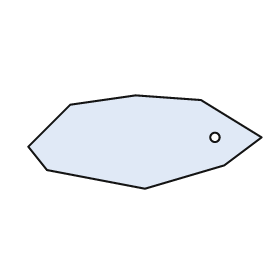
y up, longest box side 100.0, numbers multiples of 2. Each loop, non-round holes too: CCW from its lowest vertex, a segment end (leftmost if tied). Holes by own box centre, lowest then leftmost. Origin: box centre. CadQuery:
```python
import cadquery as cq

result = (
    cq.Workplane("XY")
    .moveTo(0.0, -20.0)
    .lineTo(34.0, -10.0)
    .lineTo(50.0, 2.0)
    .lineTo(24.0, 18.0)
    .lineTo(-4.0, 20.0)
    .lineTo(-32.0, 16.0)
    .lineTo(-50.0, -2.0)
    .lineTo(-42.0, -12.0)
    .close()
    .moveTo(30.0, 2.0)
    .circle(2.0)
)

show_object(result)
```